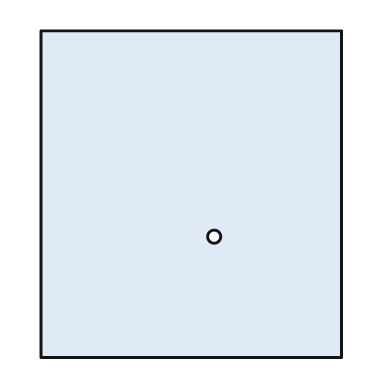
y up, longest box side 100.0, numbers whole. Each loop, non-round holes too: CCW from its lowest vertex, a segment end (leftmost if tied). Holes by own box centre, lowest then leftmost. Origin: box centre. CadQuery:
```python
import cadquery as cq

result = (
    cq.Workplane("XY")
    .moveTo(-46.0, -50.0)
    .lineTo(46.0, -50.0)
    .lineTo(46.0, 50.0)
    .lineTo(-46.0, 50.0)
    .close()
    .moveTo(7.0, -13.0)
    .circle(2.0)
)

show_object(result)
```